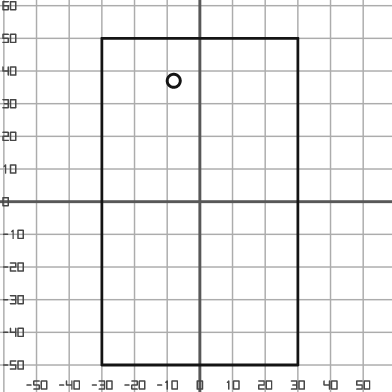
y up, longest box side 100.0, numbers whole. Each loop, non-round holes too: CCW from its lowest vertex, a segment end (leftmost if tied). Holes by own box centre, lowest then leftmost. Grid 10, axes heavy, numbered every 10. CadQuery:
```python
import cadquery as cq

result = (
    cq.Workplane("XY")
    .moveTo(-30.0, -50.0)
    .lineTo(30.0, -50.0)
    .lineTo(30.0, 50.0)
    .lineTo(-30.0, 50.0)
    .close()
    .moveTo(-8.0, 37.0)
    .circle(2.0)
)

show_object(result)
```